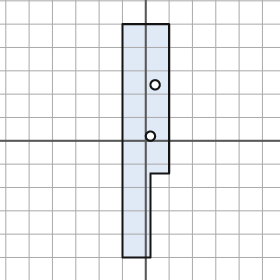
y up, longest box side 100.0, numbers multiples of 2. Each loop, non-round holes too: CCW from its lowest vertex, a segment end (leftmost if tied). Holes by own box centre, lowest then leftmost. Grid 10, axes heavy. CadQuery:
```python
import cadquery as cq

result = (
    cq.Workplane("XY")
    .moveTo(-10.0, -50.0)
    .lineTo(2.0, -50.0)
    .lineTo(2.0, -14.0)
    .lineTo(10.0, -14.0)
    .lineTo(10.0, 50.0)
    .lineTo(-10.0, 50.0)
    .close()
    .moveTo(2.0, 2.0)
    .circle(2.0)
    .moveTo(4.0, 24.0)
    .circle(2.0)
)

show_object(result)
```